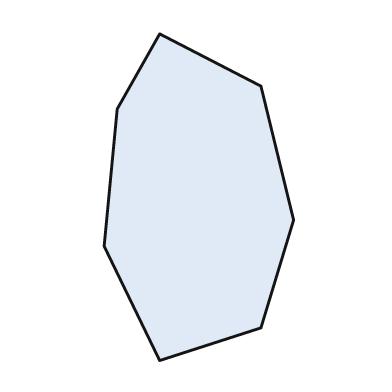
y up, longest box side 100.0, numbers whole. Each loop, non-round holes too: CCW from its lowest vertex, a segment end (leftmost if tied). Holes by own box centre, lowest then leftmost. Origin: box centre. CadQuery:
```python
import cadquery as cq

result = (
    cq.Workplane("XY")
    .moveTo(-12.0, -50.0)
    .lineTo(19.0, -40.0)
    .lineTo(29.0, -7.0)
    .lineTo(19.0, 34.0)
    .lineTo(-12.0, 50.0)
    .lineTo(-25.0, 27.0)
    .lineTo(-29.0, -15.0)
    .close()
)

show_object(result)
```